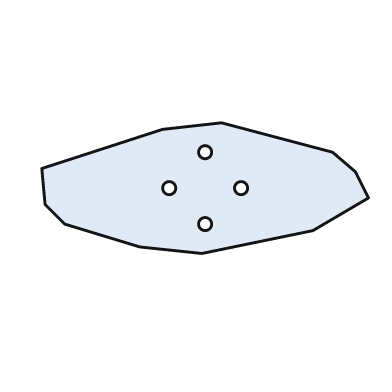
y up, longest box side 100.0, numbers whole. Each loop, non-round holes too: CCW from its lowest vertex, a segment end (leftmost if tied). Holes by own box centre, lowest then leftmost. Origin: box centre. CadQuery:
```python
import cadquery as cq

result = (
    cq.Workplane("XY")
    .moveTo(-1.0, -20.0)
    .lineTo(33.0, -13.0)
    .lineTo(50.0, -3.0)
    .lineTo(46.0, 5.0)
    .lineTo(39.0, 11.0)
    .lineTo(5.0, 20.0)
    .lineTo(-13.0, 18.0)
    .lineTo(-50.0, 6.0)
    .lineTo(-49.0, -5.0)
    .lineTo(-43.0, -11.0)
    .lineTo(-20.0, -18.0)
    .close()
    .moveTo(0.0, -11.0)
    .circle(2.0)
    .moveTo(-11.0, 0.0)
    .circle(2.0)
    .moveTo(11.0, 0.0)
    .circle(2.0)
    .moveTo(0.0, 11.0)
    .circle(2.0)
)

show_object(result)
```